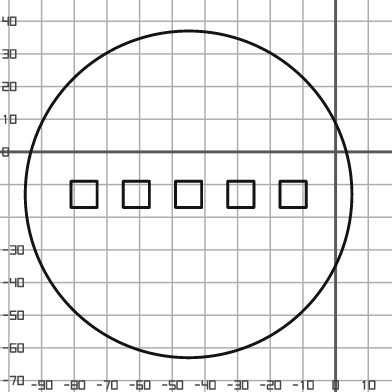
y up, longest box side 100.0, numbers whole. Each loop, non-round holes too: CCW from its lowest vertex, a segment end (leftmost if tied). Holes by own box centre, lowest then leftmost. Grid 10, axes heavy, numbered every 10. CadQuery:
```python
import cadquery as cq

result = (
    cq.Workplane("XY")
    .moveTo(-45.0, -13.0)
    .circle(50.0)
    .moveTo(-81.0, -17.0)
    .lineTo(-73.0, -17.0)
    .lineTo(-73.0, -9.0)
    .lineTo(-81.0, -9.0)
    .close()
    .moveTo(-65.0, -17.0)
    .lineTo(-57.0, -17.0)
    .lineTo(-57.0, -9.0)
    .lineTo(-65.0, -9.0)
    .close()
    .moveTo(-49.0, -17.0)
    .lineTo(-41.0, -17.0)
    .lineTo(-41.0, -9.0)
    .lineTo(-49.0, -9.0)
    .close()
    .moveTo(-33.0, -17.0)
    .lineTo(-25.0, -17.0)
    .lineTo(-25.0, -9.0)
    .lineTo(-33.0, -9.0)
    .close()
    .moveTo(-17.0, -17.0)
    .lineTo(-9.0, -17.0)
    .lineTo(-9.0, -9.0)
    .lineTo(-17.0, -9.0)
    .close()
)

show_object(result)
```